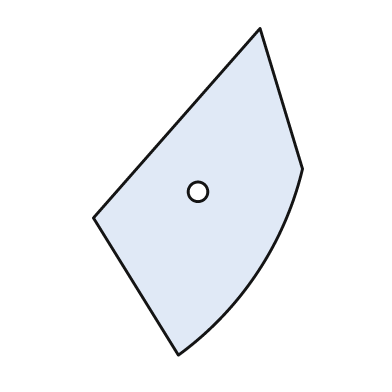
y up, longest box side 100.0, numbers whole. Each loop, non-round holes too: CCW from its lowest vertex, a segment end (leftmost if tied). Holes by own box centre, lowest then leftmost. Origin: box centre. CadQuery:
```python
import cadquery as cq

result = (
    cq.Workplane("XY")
    .moveTo(-6.0, -50.0)
    .threePointArc((18.0, -25.0), (32.0, 7.0))
    .lineTo(19.0, 50.0)
    .lineTo(-32.0, -8.0)
    .close()
    .moveTo(0.0, 0.0)
    .circle(3.0)
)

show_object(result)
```